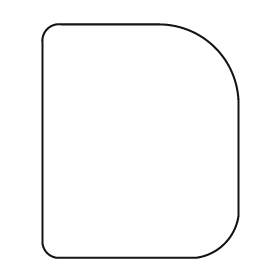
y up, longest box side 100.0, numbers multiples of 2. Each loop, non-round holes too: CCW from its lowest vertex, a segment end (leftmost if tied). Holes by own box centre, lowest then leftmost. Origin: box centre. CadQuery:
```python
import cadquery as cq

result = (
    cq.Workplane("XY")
    .moveTo(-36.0, -50.0)
    .lineTo(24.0, -50.0)
    .threePointArc((36.0, -44.0), (42.0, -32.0))
    .lineTo(42.0, 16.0)
    .threePointArc((32.0, 40.0), (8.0, 50.0))
    .lineTo(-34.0, 50.0)
    .threePointArc((-40.0, 48.0), (-42.0, 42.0))
    .lineTo(-42.0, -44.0)
    .threePointArc((-40.0, -48.0), (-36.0, -50.0))
    .close()
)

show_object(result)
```